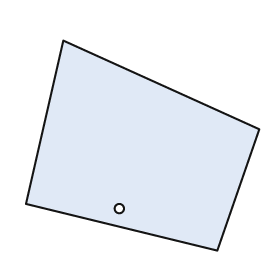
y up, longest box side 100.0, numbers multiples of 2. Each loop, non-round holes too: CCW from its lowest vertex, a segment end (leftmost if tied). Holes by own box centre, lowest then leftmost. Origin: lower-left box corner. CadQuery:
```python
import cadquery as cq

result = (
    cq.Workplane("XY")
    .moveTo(82.0, 0.0)
    .lineTo(100.0, 52.0)
    .lineTo(16.0, 90.0)
    .lineTo(0.0, 20.0)
    .close()
    .moveTo(40.0, 18.0)
    .circle(2.0)
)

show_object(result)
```